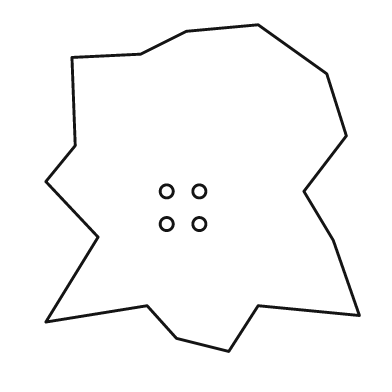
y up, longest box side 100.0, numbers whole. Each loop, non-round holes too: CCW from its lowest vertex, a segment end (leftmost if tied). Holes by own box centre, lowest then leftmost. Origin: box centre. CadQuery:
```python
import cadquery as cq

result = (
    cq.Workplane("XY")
    .moveTo(8.0, -50.0)
    .lineTo(17.0, -36.0)
    .lineTo(48.0, -39.0)
    .lineTo(40.0, -16.0)
    .lineTo(31.0, -1.0)
    .lineTo(44.0, 16.0)
    .lineTo(38.0, 35.0)
    .lineTo(17.0, 50.0)
    .lineTo(-5.0, 48.0)
    .lineTo(-19.0, 41.0)
    .lineTo(-40.0, 40.0)
    .lineTo(-39.0, 13.0)
    .lineTo(-48.0, 2.0)
    .lineTo(-32.0, -15.0)
    .lineTo(-48.0, -41.0)
    .lineTo(-17.0, -36.0)
    .lineTo(-8.0, -46.0)
    .close()
    .moveTo(-11.0, -11.0)
    .circle(2.0)
    .moveTo(-1.0, -11.0)
    .circle(2.0)
    .moveTo(-11.0, -1.0)
    .circle(2.0)
    .moveTo(-1.0, -1.0)
    .circle(2.0)
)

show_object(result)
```